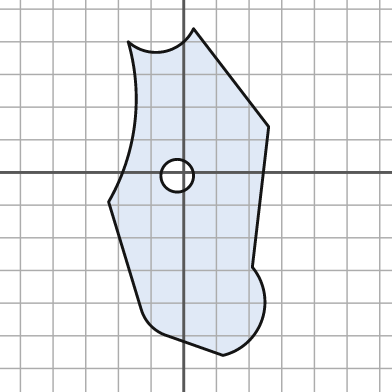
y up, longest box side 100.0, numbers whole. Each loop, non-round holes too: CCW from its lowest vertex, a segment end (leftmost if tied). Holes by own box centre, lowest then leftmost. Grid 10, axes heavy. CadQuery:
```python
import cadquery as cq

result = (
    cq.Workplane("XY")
    .moveTo(12.0, -56.0)
    .threePointArc((24.0, -45.0), (21.0, -29.0))
    .lineTo(26.0, 14.0)
    .lineTo(3.0, 44.0)
    .threePointArc((-6.0, 37.0), (-17.0, 40.0))
    .threePointArc((-15.0, 15.0), (-23.0, -9.0))
    .lineTo(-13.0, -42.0)
    .threePointArc((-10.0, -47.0), (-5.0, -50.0))
    .close()
    .moveTo(-2.0, -1.0)
    .circle(5.0)
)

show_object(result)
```